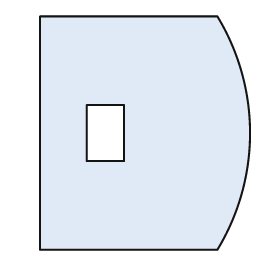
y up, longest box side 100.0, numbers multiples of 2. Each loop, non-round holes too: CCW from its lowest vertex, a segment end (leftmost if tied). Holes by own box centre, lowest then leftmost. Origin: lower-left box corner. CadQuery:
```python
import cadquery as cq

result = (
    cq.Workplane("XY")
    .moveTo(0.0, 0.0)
    .lineTo(76.0, 0.0)
    .threePointArc((90.0, 50.0), (76.0, 100.0))
    .lineTo(0.0, 100.0)
    .close()
    .moveTo(20.0, 38.0)
    .lineTo(36.0, 38.0)
    .lineTo(36.0, 62.0)
    .lineTo(20.0, 62.0)
    .close()
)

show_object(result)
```